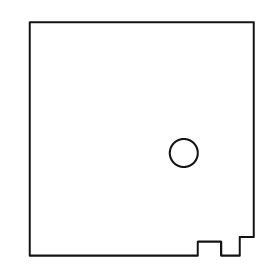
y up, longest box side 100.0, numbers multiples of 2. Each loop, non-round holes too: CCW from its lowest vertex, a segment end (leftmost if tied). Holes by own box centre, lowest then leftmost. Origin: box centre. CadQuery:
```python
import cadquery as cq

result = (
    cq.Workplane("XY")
    .moveTo(-48.0, -50.0)
    .lineTo(24.0, -50.0)
    .lineTo(24.0, -44.0)
    .lineTo(34.0, -44.0)
    .lineTo(34.0, -50.0)
    .lineTo(42.0, -50.0)
    .lineTo(42.0, -42.0)
    .lineTo(48.0, -42.0)
    .lineTo(48.0, 50.0)
    .lineTo(-48.0, 50.0)
    .close()
    .moveTo(18.0, -6.0)
    .circle(6.0)
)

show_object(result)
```